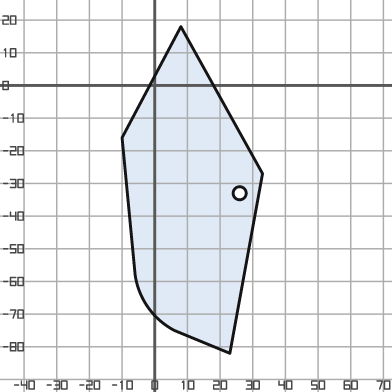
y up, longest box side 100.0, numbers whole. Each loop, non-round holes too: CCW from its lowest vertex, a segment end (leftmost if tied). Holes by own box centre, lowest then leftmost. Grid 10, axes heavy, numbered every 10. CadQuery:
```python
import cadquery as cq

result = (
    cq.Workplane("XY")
    .moveTo(23.0, -82.0)
    .lineTo(33.0, -27.0)
    .lineTo(8.0, 18.0)
    .lineTo(-10.0, -16.0)
    .lineTo(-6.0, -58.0)
    .threePointArc((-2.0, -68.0), (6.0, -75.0))
    .close()
    .moveTo(26.0, -33.0)
    .circle(2.0)
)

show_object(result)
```